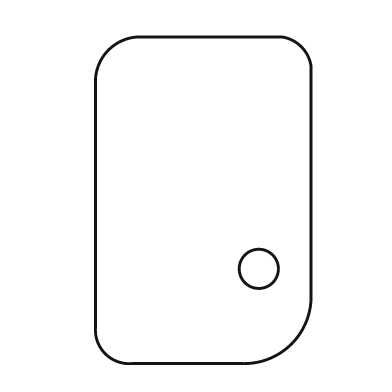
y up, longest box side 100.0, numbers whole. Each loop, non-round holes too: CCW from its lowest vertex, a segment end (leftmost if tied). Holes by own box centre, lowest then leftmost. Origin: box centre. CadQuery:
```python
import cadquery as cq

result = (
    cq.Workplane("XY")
    .moveTo(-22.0, -50.0)
    .lineTo(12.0, -50.0)
    .threePointArc((27.0, -44.0), (33.0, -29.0))
    .lineTo(33.0, 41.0)
    .threePointArc((30.0, 47.0), (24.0, 50.0))
    .lineTo(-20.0, 50.0)
    .threePointArc((-29.0, 46.0), (-33.0, 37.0))
    .lineTo(-33.0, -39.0)
    .threePointArc((-30.0, -47.0), (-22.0, -50.0))
    .close()
    .moveTo(17.0, -21.0)
    .circle(6.0)
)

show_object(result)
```